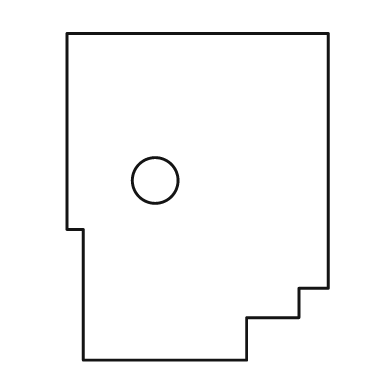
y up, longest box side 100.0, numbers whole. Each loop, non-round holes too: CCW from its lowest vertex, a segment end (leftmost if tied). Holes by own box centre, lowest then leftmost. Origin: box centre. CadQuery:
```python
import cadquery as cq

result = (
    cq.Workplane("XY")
    .moveTo(-35.0, -50.0)
    .lineTo(15.0, -50.0)
    .lineTo(15.0, -37.0)
    .lineTo(31.0, -37.0)
    .lineTo(31.0, -28.0)
    .lineTo(40.0, -28.0)
    .lineTo(40.0, 50.0)
    .lineTo(-40.0, 50.0)
    .lineTo(-40.0, -10.0)
    .lineTo(-35.0, -10.0)
    .close()
    .moveTo(-13.0, 5.0)
    .circle(7.0)
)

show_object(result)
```